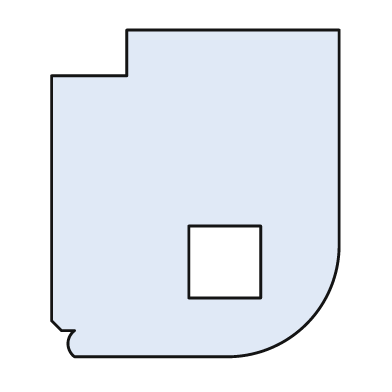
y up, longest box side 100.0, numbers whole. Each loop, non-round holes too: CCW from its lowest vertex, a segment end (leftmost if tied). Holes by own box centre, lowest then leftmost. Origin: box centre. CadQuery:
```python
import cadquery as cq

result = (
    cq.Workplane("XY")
    .moveTo(-37.0, -50.0)
    .lineTo(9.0, -50.0)
    .threePointArc((34.0, -40.0), (44.0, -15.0))
    .lineTo(44.0, 50.0)
    .lineTo(-21.0, 50.0)
    .lineTo(-21.0, 36.0)
    .lineTo(-44.0, 36.0)
    .lineTo(-44.0, -39.0)
    .lineTo(-41.0, -42.0)
    .lineTo(-37.0, -42.0)
    .threePointArc((-39.0, -46.0), (-37.0, -50.0))
    .close()
    .moveTo(-2.0, -32.0)
    .lineTo(20.0, -32.0)
    .lineTo(20.0, -10.0)
    .lineTo(-2.0, -10.0)
    .close()
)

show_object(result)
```